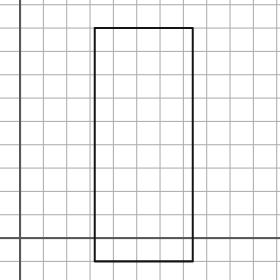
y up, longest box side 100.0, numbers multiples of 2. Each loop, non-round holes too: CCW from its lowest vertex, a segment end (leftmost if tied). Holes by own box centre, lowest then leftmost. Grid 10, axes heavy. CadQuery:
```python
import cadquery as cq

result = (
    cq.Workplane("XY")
    .moveTo(32.0, -10.0)
    .lineTo(74.0, -10.0)
    .lineTo(74.0, 90.0)
    .lineTo(32.0, 90.0)
    .close()
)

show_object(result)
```